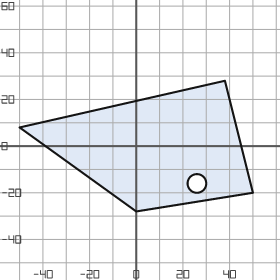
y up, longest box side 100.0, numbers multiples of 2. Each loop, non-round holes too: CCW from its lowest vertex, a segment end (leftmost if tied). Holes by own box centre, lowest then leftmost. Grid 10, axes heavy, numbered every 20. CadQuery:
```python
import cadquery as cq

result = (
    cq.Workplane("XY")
    .moveTo(0.0, -28.0)
    .lineTo(50.0, -20.0)
    .lineTo(38.0, 28.0)
    .lineTo(-50.0, 8.0)
    .close()
    .moveTo(26.0, -16.0)
    .circle(4.0)
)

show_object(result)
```